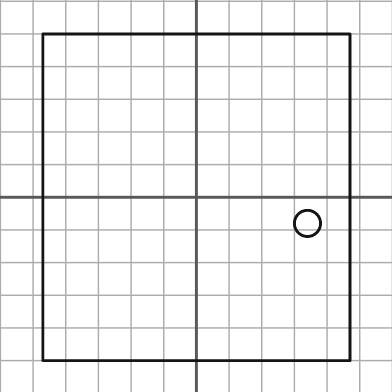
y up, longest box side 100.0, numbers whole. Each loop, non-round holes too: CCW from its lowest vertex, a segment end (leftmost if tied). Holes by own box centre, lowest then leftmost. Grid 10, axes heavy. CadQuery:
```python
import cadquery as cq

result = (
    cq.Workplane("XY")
    .moveTo(-47.0, -50.0)
    .lineTo(47.0, -50.0)
    .lineTo(47.0, 50.0)
    .lineTo(-47.0, 50.0)
    .close()
    .moveTo(34.0, -8.0)
    .circle(4.0)
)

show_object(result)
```